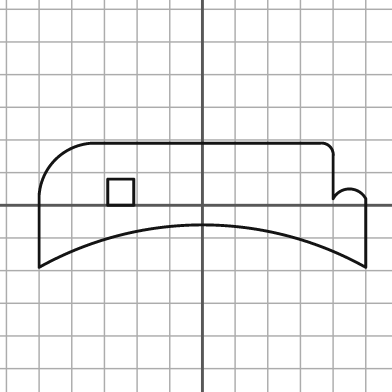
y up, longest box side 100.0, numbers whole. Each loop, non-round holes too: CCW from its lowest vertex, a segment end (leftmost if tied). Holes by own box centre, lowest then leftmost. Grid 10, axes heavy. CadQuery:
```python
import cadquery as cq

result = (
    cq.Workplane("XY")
    .moveTo(-50.0, -19.0)
    .threePointArc((0.0, -6.0), (50.0, -19.0))
    .lineTo(50.0, 2.0)
    .threePointArc((45.0, 5.0), (40.0, 2.0))
    .lineTo(40.0, 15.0)
    .threePointArc((39.0, 18.0), (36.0, 19.0))
    .lineTo(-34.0, 19.0)
    .threePointArc((-45.0, 14.0), (-50.0, 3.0))
    .close()
    .moveTo(-29.0, 0.0)
    .lineTo(-21.0, 0.0)
    .lineTo(-21.0, 8.0)
    .lineTo(-29.0, 8.0)
    .close()
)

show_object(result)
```